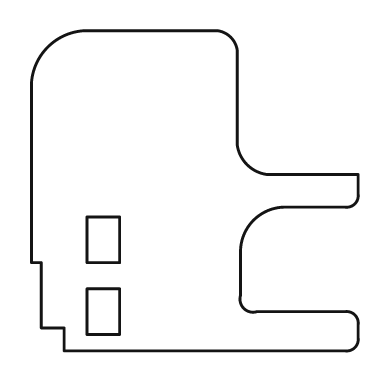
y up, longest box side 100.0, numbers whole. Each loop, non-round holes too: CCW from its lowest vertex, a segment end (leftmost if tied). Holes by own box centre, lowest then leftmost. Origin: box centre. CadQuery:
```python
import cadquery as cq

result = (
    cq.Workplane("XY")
    .moveTo(-40.0, -49.0)
    .lineTo(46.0, -49.0)
    .threePointArc((49.0, -48.0), (50.0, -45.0))
    .lineTo(50.0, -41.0)
    .threePointArc((49.0, -38.0), (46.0, -37.0))
    .lineTo(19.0, -37.0)
    .threePointArc((15.0, -36.0), (14.0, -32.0))
    .lineTo(14.0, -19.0)
    .threePointArc((18.0, -9.0), (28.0, -5.0))
    .lineTo(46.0, -5.0)
    .threePointArc((49.0, -4.0), (50.0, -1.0))
    .lineTo(50.0, 5.0)
    .lineTo(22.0, 5.0)
    .threePointArc((16.0, 8.0), (13.0, 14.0))
    .lineTo(13.0, 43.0)
    .threePointArc((11.0, 47.0), (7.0, 49.0))
    .lineTo(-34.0, 49.0)
    .threePointArc((-45.0, 44.0), (-50.0, 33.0))
    .lineTo(-50.0, -22.0)
    .lineTo(-47.0, -22.0)
    .lineTo(-47.0, -42.0)
    .lineTo(-40.0, -42.0)
    .close()
    .moveTo(-33.0, -44.0)
    .lineTo(-23.0, -44.0)
    .lineTo(-23.0, -30.0)
    .lineTo(-33.0, -30.0)
    .close()
    .moveTo(-33.0, -22.0)
    .lineTo(-23.0, -22.0)
    .lineTo(-23.0, -8.0)
    .lineTo(-33.0, -8.0)
    .close()
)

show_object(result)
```